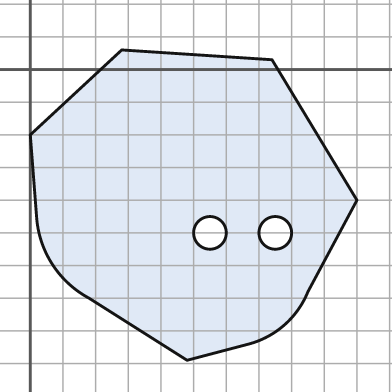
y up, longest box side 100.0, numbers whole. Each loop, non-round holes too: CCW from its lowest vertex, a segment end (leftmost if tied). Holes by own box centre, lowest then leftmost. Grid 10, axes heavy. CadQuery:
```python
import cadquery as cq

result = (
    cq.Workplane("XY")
    .moveTo(48.0, -89.0)
    .lineTo(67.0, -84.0)
    .threePointArc((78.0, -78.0), (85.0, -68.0))
    .lineTo(100.0, -40.0)
    .lineTo(74.0, 3.0)
    .lineTo(28.0, 6.0)
    .lineTo(0.0, -20.0)
    .lineTo(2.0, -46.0)
    .threePointArc((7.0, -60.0), (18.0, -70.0))
    .close()
    .moveTo(55.0, -50.0)
    .circle(5.0)
    .moveTo(75.0, -50.0)
    .circle(5.0)
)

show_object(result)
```